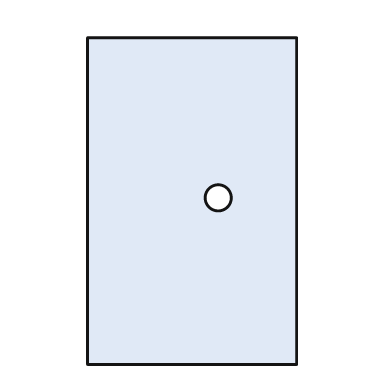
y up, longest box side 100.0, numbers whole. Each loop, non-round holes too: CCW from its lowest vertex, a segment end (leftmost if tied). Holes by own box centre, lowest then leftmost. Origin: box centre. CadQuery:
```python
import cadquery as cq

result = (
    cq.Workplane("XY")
    .moveTo(-32.0, -50.0)
    .lineTo(32.0, -50.0)
    .lineTo(32.0, 50.0)
    .lineTo(-32.0, 50.0)
    .close()
    .moveTo(8.0, 1.0)
    .circle(4.0)
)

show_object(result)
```